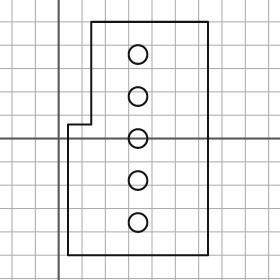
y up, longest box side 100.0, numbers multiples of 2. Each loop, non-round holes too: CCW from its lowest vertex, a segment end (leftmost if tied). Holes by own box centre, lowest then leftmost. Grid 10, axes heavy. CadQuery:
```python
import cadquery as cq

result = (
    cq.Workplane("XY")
    .moveTo(4.0, -50.0)
    .lineTo(64.0, -50.0)
    .lineTo(64.0, 50.0)
    .lineTo(14.0, 50.0)
    .lineTo(14.0, 6.0)
    .lineTo(4.0, 6.0)
    .close()
    .moveTo(34.0, -36.0)
    .circle(4.0)
    .moveTo(34.0, -18.0)
    .circle(4.0)
    .moveTo(34.0, 0.0)
    .circle(4.0)
    .moveTo(34.0, 18.0)
    .circle(4.0)
    .moveTo(34.0, 36.0)
    .circle(4.0)
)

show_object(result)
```